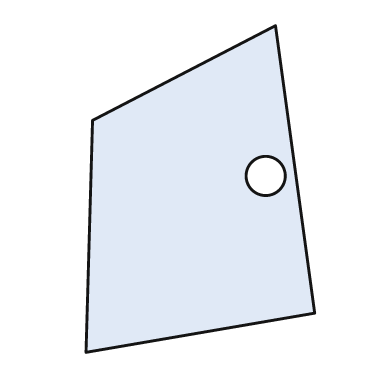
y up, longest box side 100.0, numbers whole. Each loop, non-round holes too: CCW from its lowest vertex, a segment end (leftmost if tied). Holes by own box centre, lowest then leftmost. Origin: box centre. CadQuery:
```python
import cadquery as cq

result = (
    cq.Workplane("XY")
    .moveTo(-35.0, -50.0)
    .lineTo(35.0, -38.0)
    .lineTo(23.0, 50.0)
    .lineTo(-33.0, 21.0)
    .close()
    .moveTo(20.0, 4.0)
    .circle(6.0)
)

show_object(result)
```